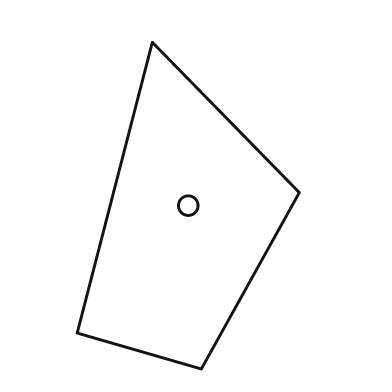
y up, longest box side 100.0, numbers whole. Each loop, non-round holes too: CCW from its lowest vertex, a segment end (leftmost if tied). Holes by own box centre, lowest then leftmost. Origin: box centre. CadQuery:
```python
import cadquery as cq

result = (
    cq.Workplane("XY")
    .moveTo(4.0, -50.0)
    .lineTo(34.0, 4.0)
    .lineTo(-11.0, 50.0)
    .lineTo(-34.0, -39.0)
    .close()
    .moveTo(0.0, 0.0)
    .circle(3.0)
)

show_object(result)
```